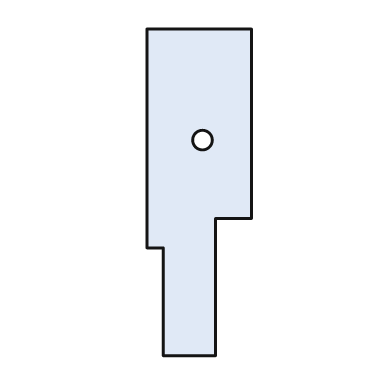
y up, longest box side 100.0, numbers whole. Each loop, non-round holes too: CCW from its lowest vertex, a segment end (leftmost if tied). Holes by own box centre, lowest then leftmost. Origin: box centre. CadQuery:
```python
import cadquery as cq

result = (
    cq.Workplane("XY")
    .moveTo(-11.0, -50.0)
    .lineTo(5.0, -50.0)
    .lineTo(5.0, -8.0)
    .lineTo(16.0, -8.0)
    .lineTo(16.0, 50.0)
    .lineTo(-16.0, 50.0)
    .lineTo(-16.0, -17.0)
    .lineTo(-11.0, -17.0)
    .close()
    .moveTo(1.0, 16.0)
    .circle(3.0)
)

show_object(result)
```